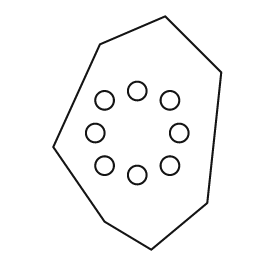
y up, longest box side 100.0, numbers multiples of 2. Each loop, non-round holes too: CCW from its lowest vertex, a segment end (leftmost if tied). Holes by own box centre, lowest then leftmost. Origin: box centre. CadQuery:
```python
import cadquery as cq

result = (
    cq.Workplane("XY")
    .moveTo(6.0, -50.0)
    .lineTo(30.0, -30.0)
    .lineTo(36.0, 26.0)
    .lineTo(12.0, 50.0)
    .lineTo(-16.0, 38.0)
    .lineTo(-36.0, -6.0)
    .lineTo(-14.0, -38.0)
    .close()
    .moveTo(0.0, -18.0)
    .circle(4.0)
    .moveTo(-14.0, -14.0)
    .circle(4.0)
    .moveTo(14.0, -14.0)
    .circle(4.0)
    .moveTo(-18.0, 0.0)
    .circle(4.0)
    .moveTo(18.0, 0.0)
    .circle(4.0)
    .moveTo(-14.0, 14.0)
    .circle(4.0)
    .moveTo(14.0, 14.0)
    .circle(4.0)
    .moveTo(0.0, 18.0)
    .circle(4.0)
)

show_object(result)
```